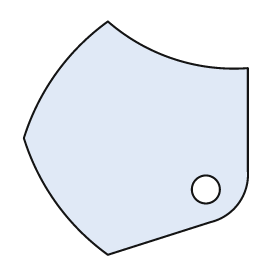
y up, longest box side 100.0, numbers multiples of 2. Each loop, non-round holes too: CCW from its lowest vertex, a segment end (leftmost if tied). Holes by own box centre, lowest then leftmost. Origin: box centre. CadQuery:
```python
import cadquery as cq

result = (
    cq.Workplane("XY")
    .moveTo(-12.0, -50.0)
    .lineTo(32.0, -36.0)
    .threePointArc((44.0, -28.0), (48.0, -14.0))
    .lineTo(48.0, 30.0)
    .threePointArc((16.0, 34.0), (-12.0, 50.0))
    .threePointArc((-34.0, 28.0), (-48.0, 0.0))
    .threePointArc((-34.0, -28.0), (-12.0, -50.0))
    .close()
    .moveTo(30.0, -22.0)
    .circle(6.0)
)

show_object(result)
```